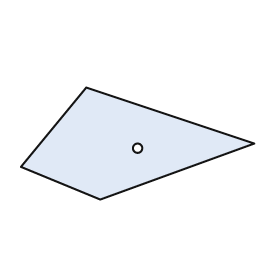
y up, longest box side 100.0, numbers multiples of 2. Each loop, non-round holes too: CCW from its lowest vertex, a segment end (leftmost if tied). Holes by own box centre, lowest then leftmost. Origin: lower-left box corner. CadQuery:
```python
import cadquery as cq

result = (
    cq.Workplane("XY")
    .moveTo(34.0, 0.0)
    .lineTo(100.0, 24.0)
    .lineTo(28.0, 48.0)
    .lineTo(0.0, 14.0)
    .close()
    .moveTo(50.0, 22.0)
    .circle(2.0)
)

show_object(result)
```